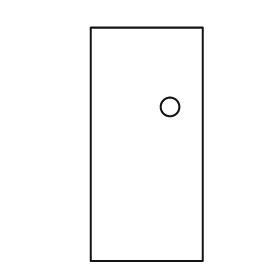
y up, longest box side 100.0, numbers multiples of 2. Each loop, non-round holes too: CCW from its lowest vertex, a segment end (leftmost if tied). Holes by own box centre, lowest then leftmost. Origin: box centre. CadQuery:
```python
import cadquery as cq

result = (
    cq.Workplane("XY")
    .moveTo(-24.0, -50.0)
    .lineTo(24.0, -50.0)
    .lineTo(24.0, 50.0)
    .lineTo(-24.0, 50.0)
    .close()
    .moveTo(10.0, 16.0)
    .circle(4.0)
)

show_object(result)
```